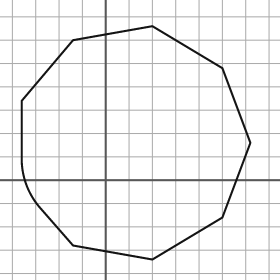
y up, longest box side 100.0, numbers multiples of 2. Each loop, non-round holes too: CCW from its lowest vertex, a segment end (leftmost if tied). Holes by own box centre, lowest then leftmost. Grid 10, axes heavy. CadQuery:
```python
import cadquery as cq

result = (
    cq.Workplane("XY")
    .moveTo(20.0, -34.0)
    .lineTo(50.0, -16.0)
    .lineTo(62.0, 16.0)
    .lineTo(50.0, 48.0)
    .lineTo(20.0, 66.0)
    .lineTo(-14.0, 60.0)
    .lineTo(-36.0, 34.0)
    .lineTo(-36.0, 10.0)
    .threePointArc((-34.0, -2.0), (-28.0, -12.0))
    .lineTo(-14.0, -28.0)
    .close()
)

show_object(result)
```